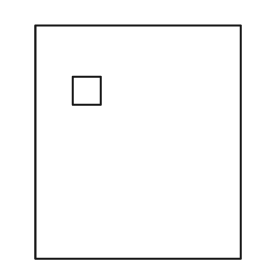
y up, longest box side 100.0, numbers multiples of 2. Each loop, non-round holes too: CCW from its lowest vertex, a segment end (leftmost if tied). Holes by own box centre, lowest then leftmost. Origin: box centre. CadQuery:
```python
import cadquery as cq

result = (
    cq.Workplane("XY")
    .moveTo(-44.0, -50.0)
    .lineTo(44.0, -50.0)
    .lineTo(44.0, 50.0)
    .lineTo(-44.0, 50.0)
    .close()
    .moveTo(-28.0, 16.0)
    .lineTo(-16.0, 16.0)
    .lineTo(-16.0, 28.0)
    .lineTo(-28.0, 28.0)
    .close()
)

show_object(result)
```